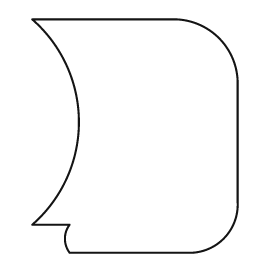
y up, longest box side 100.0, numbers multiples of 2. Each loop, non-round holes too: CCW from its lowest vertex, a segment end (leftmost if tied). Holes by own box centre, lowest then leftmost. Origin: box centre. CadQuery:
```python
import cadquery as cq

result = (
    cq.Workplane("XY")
    .moveTo(-28.0, -50.0)
    .lineTo(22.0, -50.0)
    .threePointArc((38.0, -44.0), (44.0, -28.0))
    .lineTo(44.0, 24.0)
    .threePointArc((36.0, 42.0), (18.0, 50.0))
    .lineTo(-44.0, 50.0)
    .threePointArc((-24.0, 6.0), (-44.0, -38.0))
    .lineTo(-28.0, -38.0)
    .threePointArc((-30.0, -44.0), (-28.0, -50.0))
    .close()
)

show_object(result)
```